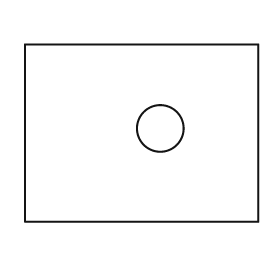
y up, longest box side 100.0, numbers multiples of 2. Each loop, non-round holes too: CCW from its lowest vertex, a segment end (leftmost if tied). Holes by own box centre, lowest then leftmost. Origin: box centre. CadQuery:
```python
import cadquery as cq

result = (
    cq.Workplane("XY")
    .moveTo(-50.0, -38.0)
    .lineTo(50.0, -38.0)
    .lineTo(50.0, 38.0)
    .lineTo(-50.0, 38.0)
    .close()
    .moveTo(8.0, 2.0)
    .circle(10.0)
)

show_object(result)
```